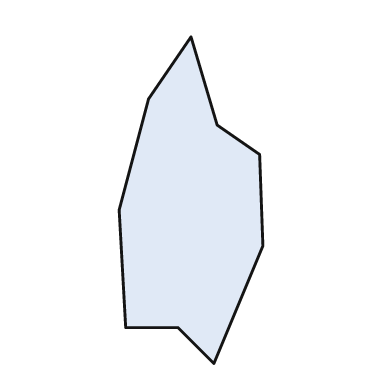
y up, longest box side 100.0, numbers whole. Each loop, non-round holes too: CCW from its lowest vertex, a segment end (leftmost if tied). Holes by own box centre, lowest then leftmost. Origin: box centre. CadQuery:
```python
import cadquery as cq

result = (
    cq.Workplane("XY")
    .moveTo(7.0, -50.0)
    .lineTo(22.0, -14.0)
    .lineTo(21.0, 14.0)
    .lineTo(8.0, 23.0)
    .lineTo(0.0, 50.0)
    .lineTo(-13.0, 31.0)
    .lineTo(-22.0, -3.0)
    .lineTo(-20.0, -39.0)
    .lineTo(-4.0, -39.0)
    .close()
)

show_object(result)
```